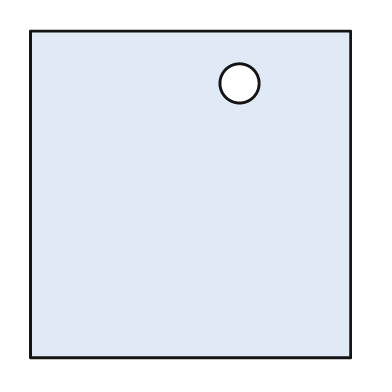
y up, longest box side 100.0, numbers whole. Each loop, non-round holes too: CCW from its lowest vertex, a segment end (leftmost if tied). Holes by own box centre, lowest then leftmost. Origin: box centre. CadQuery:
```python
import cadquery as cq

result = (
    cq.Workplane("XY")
    .moveTo(-49.0, -50.0)
    .lineTo(49.0, -50.0)
    .lineTo(49.0, 50.0)
    .lineTo(-49.0, 50.0)
    .close()
    .moveTo(15.0, 34.0)
    .circle(6.0)
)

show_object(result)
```